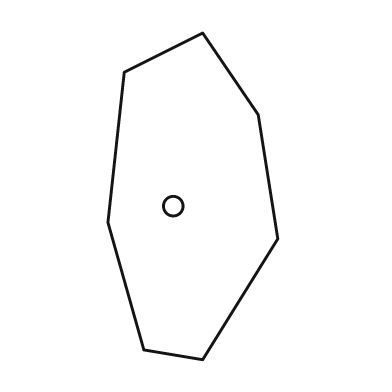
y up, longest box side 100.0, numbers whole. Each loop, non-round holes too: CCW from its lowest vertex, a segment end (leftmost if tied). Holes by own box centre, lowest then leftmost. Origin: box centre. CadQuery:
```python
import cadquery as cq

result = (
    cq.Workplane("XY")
    .moveTo(3.0, -50.0)
    .lineTo(26.0, -13.0)
    .lineTo(20.0, 25.0)
    .lineTo(3.0, 50.0)
    .lineTo(-21.0, 38.0)
    .lineTo(-26.0, -8.0)
    .lineTo(-15.0, -47.0)
    .close()
    .moveTo(-6.0, -3.0)
    .circle(3.0)
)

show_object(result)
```